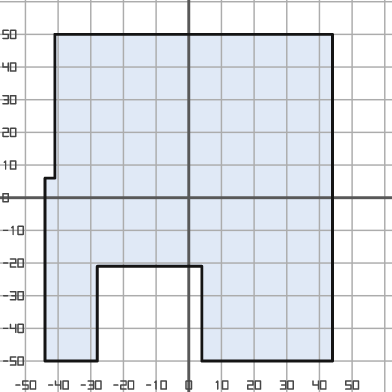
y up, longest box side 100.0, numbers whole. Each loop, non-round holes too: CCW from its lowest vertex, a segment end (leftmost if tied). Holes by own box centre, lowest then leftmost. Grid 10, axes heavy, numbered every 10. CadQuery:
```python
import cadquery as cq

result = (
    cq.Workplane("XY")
    .moveTo(-44.0, -50.0)
    .lineTo(-28.0, -50.0)
    .lineTo(-28.0, -21.0)
    .lineTo(4.0, -21.0)
    .lineTo(4.0, -50.0)
    .lineTo(44.0, -50.0)
    .lineTo(44.0, 50.0)
    .lineTo(-41.0, 50.0)
    .lineTo(-41.0, 6.0)
    .lineTo(-44.0, 6.0)
    .close()
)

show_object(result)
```